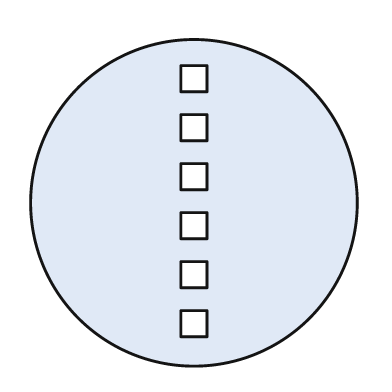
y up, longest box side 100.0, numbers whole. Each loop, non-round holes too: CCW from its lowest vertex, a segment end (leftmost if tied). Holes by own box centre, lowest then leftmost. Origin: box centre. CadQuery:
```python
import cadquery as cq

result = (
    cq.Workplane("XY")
    .moveTo(0.0, 0.0)
    .circle(50.0)
    .moveTo(-4.0, -41.0)
    .lineTo(4.0, -41.0)
    .lineTo(4.0, -33.0)
    .lineTo(-4.0, -33.0)
    .close()
    .moveTo(-4.0, -26.0)
    .lineTo(4.0, -26.0)
    .lineTo(4.0, -18.0)
    .lineTo(-4.0, -18.0)
    .close()
    .moveTo(-4.0, -11.0)
    .lineTo(4.0, -11.0)
    .lineTo(4.0, -3.0)
    .lineTo(-4.0, -3.0)
    .close()
    .moveTo(-4.0, 4.0)
    .lineTo(4.0, 4.0)
    .lineTo(4.0, 12.0)
    .lineTo(-4.0, 12.0)
    .close()
    .moveTo(-4.0, 19.0)
    .lineTo(4.0, 19.0)
    .lineTo(4.0, 27.0)
    .lineTo(-4.0, 27.0)
    .close()
    .moveTo(-4.0, 34.0)
    .lineTo(4.0, 34.0)
    .lineTo(4.0, 42.0)
    .lineTo(-4.0, 42.0)
    .close()
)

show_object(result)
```